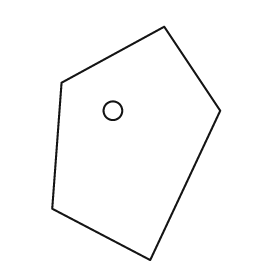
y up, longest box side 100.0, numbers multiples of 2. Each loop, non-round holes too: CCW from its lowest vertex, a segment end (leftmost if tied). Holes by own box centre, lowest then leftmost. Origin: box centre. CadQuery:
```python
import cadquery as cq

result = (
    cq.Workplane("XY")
    .moveTo(6.0, -50.0)
    .lineTo(36.0, 14.0)
    .lineTo(12.0, 50.0)
    .lineTo(-32.0, 26.0)
    .lineTo(-36.0, -28.0)
    .close()
    .moveTo(-10.0, 14.0)
    .circle(4.0)
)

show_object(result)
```